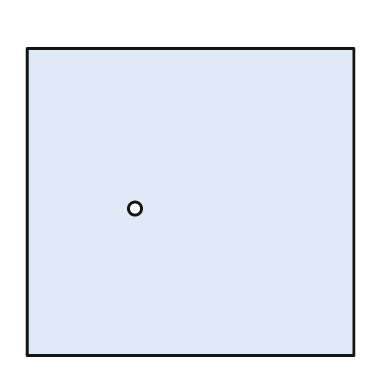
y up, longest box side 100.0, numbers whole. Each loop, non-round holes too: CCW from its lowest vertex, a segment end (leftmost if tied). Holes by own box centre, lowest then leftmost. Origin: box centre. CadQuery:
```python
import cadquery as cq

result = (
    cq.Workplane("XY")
    .moveTo(-50.0, -47.0)
    .lineTo(50.0, -47.0)
    .lineTo(50.0, 47.0)
    .lineTo(-50.0, 47.0)
    .close()
    .moveTo(-17.0, -2.0)
    .circle(2.0)
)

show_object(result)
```